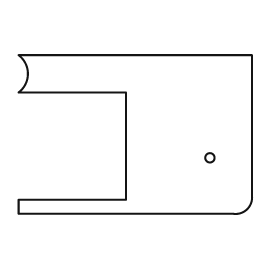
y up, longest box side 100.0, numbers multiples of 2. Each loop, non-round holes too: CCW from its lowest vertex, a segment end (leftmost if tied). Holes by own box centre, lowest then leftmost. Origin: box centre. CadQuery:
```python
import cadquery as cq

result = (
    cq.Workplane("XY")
    .moveTo(-50.0, -34.0)
    .lineTo(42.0, -34.0)
    .threePointArc((48.0, -32.0), (50.0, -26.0))
    .lineTo(50.0, 34.0)
    .lineTo(-50.0, 34.0)
    .threePointArc((-46.0, 26.0), (-50.0, 18.0))
    .lineTo(-4.0, 18.0)
    .lineTo(-4.0, -28.0)
    .lineTo(-50.0, -28.0)
    .close()
    .moveTo(32.0, -10.0)
    .circle(2.0)
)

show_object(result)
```